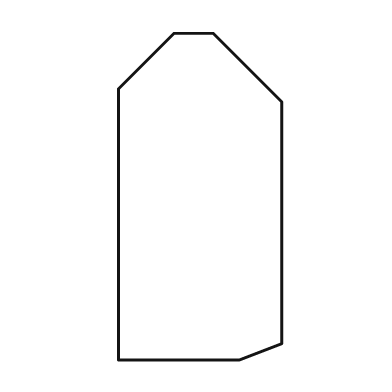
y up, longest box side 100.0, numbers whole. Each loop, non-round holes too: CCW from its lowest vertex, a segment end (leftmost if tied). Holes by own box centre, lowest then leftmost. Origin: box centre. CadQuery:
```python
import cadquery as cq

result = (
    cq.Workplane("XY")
    .moveTo(-25.0, -50.0)
    .lineTo(12.0, -50.0)
    .lineTo(25.0, -45.0)
    .lineTo(25.0, 29.0)
    .lineTo(4.0, 50.0)
    .lineTo(-8.0, 50.0)
    .lineTo(-25.0, 33.0)
    .close()
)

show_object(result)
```